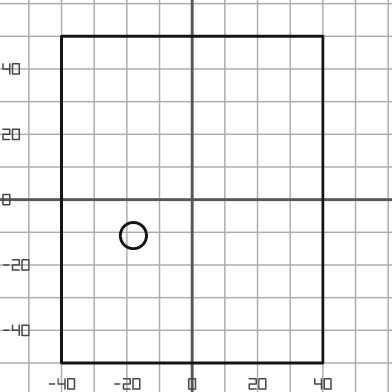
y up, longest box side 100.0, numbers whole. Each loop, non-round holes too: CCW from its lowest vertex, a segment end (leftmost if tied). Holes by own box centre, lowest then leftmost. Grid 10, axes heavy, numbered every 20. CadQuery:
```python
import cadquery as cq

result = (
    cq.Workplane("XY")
    .moveTo(-40.0, -50.0)
    .lineTo(40.0, -50.0)
    .lineTo(40.0, 50.0)
    .lineTo(-40.0, 50.0)
    .close()
    .moveTo(-18.0, -11.0)
    .circle(4.0)
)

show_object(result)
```